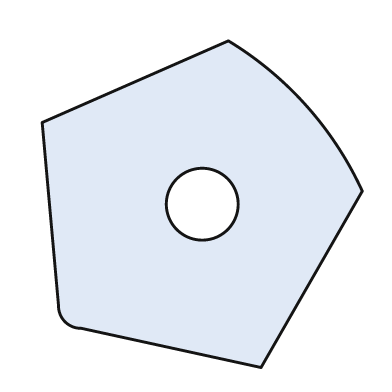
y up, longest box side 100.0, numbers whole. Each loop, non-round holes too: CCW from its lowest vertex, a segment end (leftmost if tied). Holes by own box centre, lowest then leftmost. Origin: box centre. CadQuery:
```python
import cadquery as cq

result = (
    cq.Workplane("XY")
    .moveTo(18.0, -50.0)
    .lineTo(49.0, 4.0)
    .threePointArc((32.0, 30.0), (8.0, 50.0))
    .lineTo(-49.0, 25.0)
    .lineTo(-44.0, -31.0)
    .threePointArc((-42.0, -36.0), (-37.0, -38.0))
    .close()
    .moveTo(0.0, 0.0)
    .circle(11.0)
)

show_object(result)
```